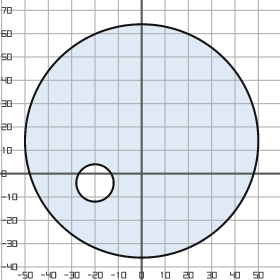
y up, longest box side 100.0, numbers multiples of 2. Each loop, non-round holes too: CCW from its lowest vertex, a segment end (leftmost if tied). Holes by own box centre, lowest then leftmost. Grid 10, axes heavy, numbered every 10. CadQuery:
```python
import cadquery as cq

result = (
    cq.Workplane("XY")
    .moveTo(0.0, 14.0)
    .circle(50.0)
    .moveTo(-20.0, -4.0)
    .circle(8.0)
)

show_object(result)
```